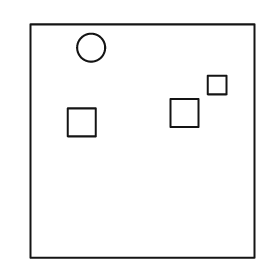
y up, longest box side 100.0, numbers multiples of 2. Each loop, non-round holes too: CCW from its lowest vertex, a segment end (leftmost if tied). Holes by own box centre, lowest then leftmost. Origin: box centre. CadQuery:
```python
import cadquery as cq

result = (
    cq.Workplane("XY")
    .moveTo(-48.0, -50.0)
    .lineTo(48.0, -50.0)
    .lineTo(48.0, 50.0)
    .lineTo(-48.0, 50.0)
    .close()
    .moveTo(-32.0, 2.0)
    .lineTo(-20.0, 2.0)
    .lineTo(-20.0, 14.0)
    .lineTo(-32.0, 14.0)
    .close()
    .moveTo(12.0, 6.0)
    .lineTo(24.0, 6.0)
    .lineTo(24.0, 18.0)
    .lineTo(12.0, 18.0)
    .close()
    .moveTo(28.0, 20.0)
    .lineTo(36.0, 20.0)
    .lineTo(36.0, 28.0)
    .lineTo(28.0, 28.0)
    .close()
    .moveTo(-22.0, 40.0)
    .circle(6.0)
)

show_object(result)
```